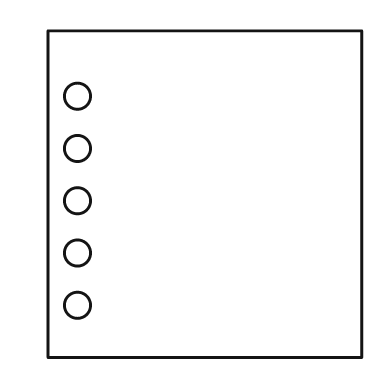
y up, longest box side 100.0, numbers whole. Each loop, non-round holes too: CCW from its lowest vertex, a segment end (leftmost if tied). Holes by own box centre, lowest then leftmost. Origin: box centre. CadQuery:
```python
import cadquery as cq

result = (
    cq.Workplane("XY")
    .moveTo(-48.0, -50.0)
    .lineTo(48.0, -50.0)
    .lineTo(48.0, 50.0)
    .lineTo(-48.0, 50.0)
    .close()
    .moveTo(-39.0, -34.0)
    .circle(4.0)
    .moveTo(-39.0, -18.0)
    .circle(4.0)
    .moveTo(-39.0, -2.0)
    .circle(4.0)
    .moveTo(-39.0, 14.0)
    .circle(4.0)
    .moveTo(-39.0, 30.0)
    .circle(4.0)
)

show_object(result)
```